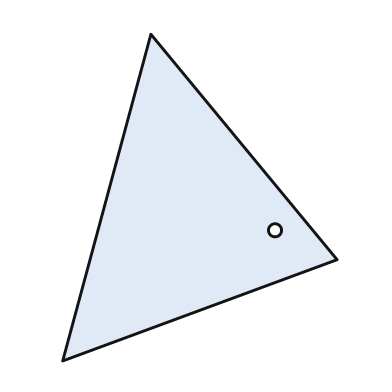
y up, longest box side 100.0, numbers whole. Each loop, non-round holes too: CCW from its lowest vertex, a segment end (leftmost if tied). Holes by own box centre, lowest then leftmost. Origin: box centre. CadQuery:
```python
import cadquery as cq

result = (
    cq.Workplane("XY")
    .moveTo(-42.0, -50.0)
    .lineTo(42.0, -19.0)
    .lineTo(-15.0, 50.0)
    .close()
    .moveTo(23.0, -10.0)
    .circle(2.0)
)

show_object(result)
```